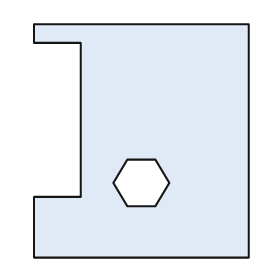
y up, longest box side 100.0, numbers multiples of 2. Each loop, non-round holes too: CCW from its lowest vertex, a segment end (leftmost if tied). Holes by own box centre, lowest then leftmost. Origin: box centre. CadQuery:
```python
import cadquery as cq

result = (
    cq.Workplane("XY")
    .moveTo(-46.0, -50.0)
    .lineTo(46.0, -50.0)
    .lineTo(46.0, 50.0)
    .lineTo(-46.0, 50.0)
    .lineTo(-46.0, 42.0)
    .lineTo(-26.0, 42.0)
    .lineTo(-26.0, -24.0)
    .lineTo(-46.0, -24.0)
    .close()
    .moveTo(-6.0, -28.0)
    .lineTo(6.0, -28.0)
    .lineTo(12.0, -18.0)
    .lineTo(6.0, -8.0)
    .lineTo(-6.0, -8.0)
    .lineTo(-12.0, -18.0)
    .close()
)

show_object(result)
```